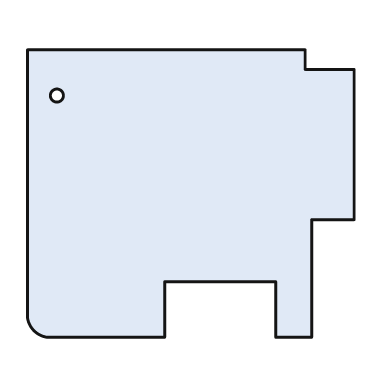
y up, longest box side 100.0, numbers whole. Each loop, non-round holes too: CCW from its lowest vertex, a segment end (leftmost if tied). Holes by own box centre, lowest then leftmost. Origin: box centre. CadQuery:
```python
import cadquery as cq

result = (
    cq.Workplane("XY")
    .moveTo(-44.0, -44.0)
    .lineTo(-8.0, -44.0)
    .lineTo(-8.0, -27.0)
    .lineTo(26.0, -27.0)
    .lineTo(26.0, -44.0)
    .lineTo(37.0, -44.0)
    .lineTo(37.0, -8.0)
    .lineTo(50.0, -8.0)
    .lineTo(50.0, 38.0)
    .lineTo(35.0, 38.0)
    .lineTo(35.0, 44.0)
    .lineTo(-50.0, 44.0)
    .lineTo(-50.0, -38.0)
    .threePointArc((-48.0, -42.0), (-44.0, -44.0))
    .close()
    .moveTo(-41.0, 30.0)
    .circle(2.0)
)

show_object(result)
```